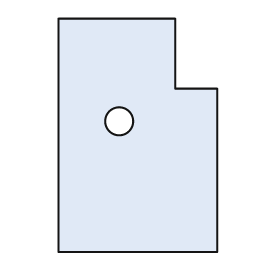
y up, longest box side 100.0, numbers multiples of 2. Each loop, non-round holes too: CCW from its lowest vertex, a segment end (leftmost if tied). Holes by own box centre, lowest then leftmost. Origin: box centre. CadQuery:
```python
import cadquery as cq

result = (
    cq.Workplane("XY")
    .moveTo(-34.0, -50.0)
    .lineTo(34.0, -50.0)
    .lineTo(34.0, 20.0)
    .lineTo(16.0, 20.0)
    .lineTo(16.0, 50.0)
    .lineTo(-34.0, 50.0)
    .close()
    .moveTo(-8.0, 6.0)
    .circle(6.0)
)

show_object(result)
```